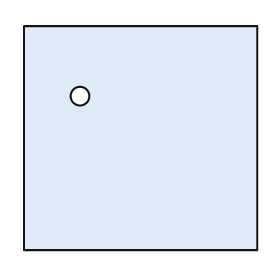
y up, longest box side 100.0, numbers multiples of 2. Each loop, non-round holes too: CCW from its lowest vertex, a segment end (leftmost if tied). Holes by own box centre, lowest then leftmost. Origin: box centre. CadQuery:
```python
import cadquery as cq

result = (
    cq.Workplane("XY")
    .moveTo(-50.0, -48.0)
    .lineTo(50.0, -48.0)
    .lineTo(50.0, 48.0)
    .lineTo(-50.0, 48.0)
    .close()
    .moveTo(-26.0, 18.0)
    .circle(4.0)
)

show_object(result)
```